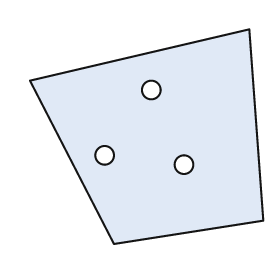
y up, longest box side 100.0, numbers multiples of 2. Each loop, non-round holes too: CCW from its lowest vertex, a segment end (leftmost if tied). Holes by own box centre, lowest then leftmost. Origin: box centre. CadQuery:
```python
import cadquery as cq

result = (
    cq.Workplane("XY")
    .moveTo(-14.0, -46.0)
    .lineTo(50.0, -36.0)
    .lineTo(44.0, 46.0)
    .lineTo(-50.0, 24.0)
    .close()
    .moveTo(16.0, -12.0)
    .circle(4.0)
    .moveTo(-18.0, -8.0)
    .circle(4.0)
    .moveTo(2.0, 20.0)
    .circle(4.0)
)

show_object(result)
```